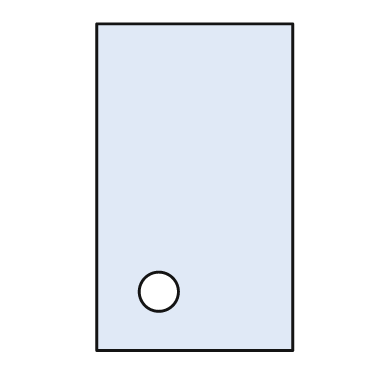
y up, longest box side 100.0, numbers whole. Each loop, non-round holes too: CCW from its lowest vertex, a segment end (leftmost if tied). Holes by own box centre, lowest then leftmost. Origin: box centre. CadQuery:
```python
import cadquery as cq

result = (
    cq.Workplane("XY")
    .moveTo(-30.0, -50.0)
    .lineTo(30.0, -50.0)
    .lineTo(30.0, 50.0)
    .lineTo(-30.0, 50.0)
    .close()
    .moveTo(-11.0, -32.0)
    .circle(6.0)
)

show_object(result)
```